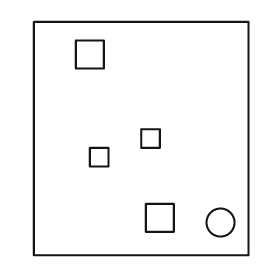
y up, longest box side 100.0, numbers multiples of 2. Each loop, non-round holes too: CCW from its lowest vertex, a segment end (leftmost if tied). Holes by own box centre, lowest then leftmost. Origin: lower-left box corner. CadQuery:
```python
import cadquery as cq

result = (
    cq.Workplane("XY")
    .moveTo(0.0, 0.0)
    .lineTo(92.0, 0.0)
    .lineTo(92.0, 100.0)
    .lineTo(0.0, 100.0)
    .close()
    .moveTo(80.0, 14.0)
    .circle(6.0)
    .moveTo(48.0, 10.0)
    .lineTo(60.0, 10.0)
    .lineTo(60.0, 22.0)
    .lineTo(48.0, 22.0)
    .close()
    .moveTo(24.0, 38.0)
    .lineTo(32.0, 38.0)
    .lineTo(32.0, 46.0)
    .lineTo(24.0, 46.0)
    .close()
    .moveTo(46.0, 46.0)
    .lineTo(54.0, 46.0)
    .lineTo(54.0, 54.0)
    .lineTo(46.0, 54.0)
    .close()
    .moveTo(18.0, 80.0)
    .lineTo(30.0, 80.0)
    .lineTo(30.0, 92.0)
    .lineTo(18.0, 92.0)
    .close()
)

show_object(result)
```